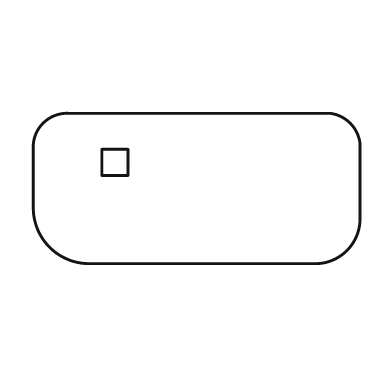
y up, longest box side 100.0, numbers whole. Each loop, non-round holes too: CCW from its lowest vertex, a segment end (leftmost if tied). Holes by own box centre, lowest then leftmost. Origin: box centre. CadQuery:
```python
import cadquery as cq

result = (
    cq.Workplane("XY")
    .moveTo(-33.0, -23.0)
    .lineTo(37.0, -23.0)
    .threePointArc((46.0, -19.0), (50.0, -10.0))
    .lineTo(50.0, 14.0)
    .threePointArc((47.0, 20.0), (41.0, 23.0))
    .lineTo(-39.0, 23.0)
    .threePointArc((-47.0, 20.0), (-50.0, 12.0))
    .lineTo(-50.0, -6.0)
    .threePointArc((-45.0, -18.0), (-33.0, -23.0))
    .close()
    .moveTo(-29.0, 4.0)
    .lineTo(-21.0, 4.0)
    .lineTo(-21.0, 12.0)
    .lineTo(-29.0, 12.0)
    .close()
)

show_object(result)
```